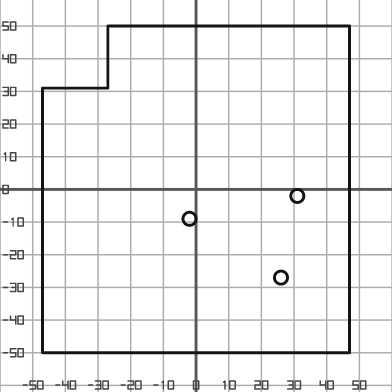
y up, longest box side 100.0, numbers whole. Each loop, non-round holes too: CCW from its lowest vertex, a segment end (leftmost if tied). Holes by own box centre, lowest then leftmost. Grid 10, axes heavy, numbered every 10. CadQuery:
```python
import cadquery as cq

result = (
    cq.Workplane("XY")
    .moveTo(-47.0, -50.0)
    .lineTo(47.0, -50.0)
    .lineTo(47.0, 50.0)
    .lineTo(-27.0, 50.0)
    .lineTo(-27.0, 31.0)
    .lineTo(-47.0, 31.0)
    .close()
    .moveTo(26.0, -27.0)
    .circle(2.0)
    .moveTo(-2.0, -9.0)
    .circle(2.0)
    .moveTo(31.0, -2.0)
    .circle(2.0)
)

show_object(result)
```